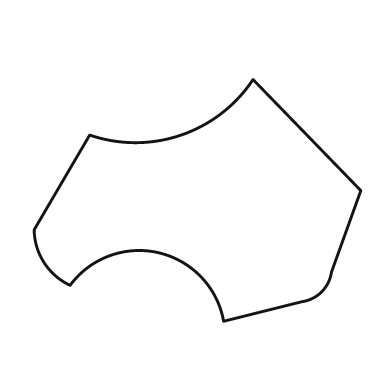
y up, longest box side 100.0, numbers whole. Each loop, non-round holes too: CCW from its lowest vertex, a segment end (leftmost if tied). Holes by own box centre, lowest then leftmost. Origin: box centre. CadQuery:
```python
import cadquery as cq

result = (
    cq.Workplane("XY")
    .moveTo(8.0, -37.0)
    .lineTo(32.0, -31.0)
    .threePointArc((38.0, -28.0), (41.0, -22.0))
    .lineTo(50.0, 3.0)
    .lineTo(17.0, 37.0)
    .threePointArc((-5.0, 20.0), (-33.0, 20.0))
    .lineTo(-50.0, -9.0)
    .threePointArc((-47.0, -19.0), (-39.0, -26.0))
    .threePointArc((-12.0, -16.0), (8.0, -37.0))
    .close()
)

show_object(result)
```